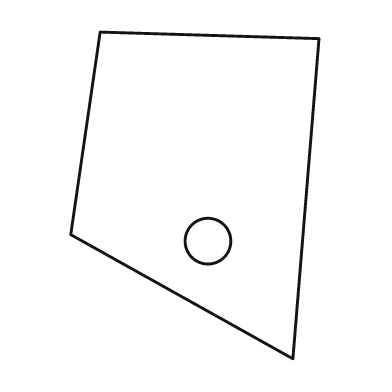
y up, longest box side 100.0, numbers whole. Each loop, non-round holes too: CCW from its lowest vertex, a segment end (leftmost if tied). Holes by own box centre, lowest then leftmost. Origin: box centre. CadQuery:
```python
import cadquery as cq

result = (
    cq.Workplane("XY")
    .moveTo(30.0, -50.0)
    .lineTo(38.0, 48.0)
    .lineTo(-29.0, 50.0)
    .lineTo(-38.0, -12.0)
    .close()
    .moveTo(4.0, -14.0)
    .circle(7.0)
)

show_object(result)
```